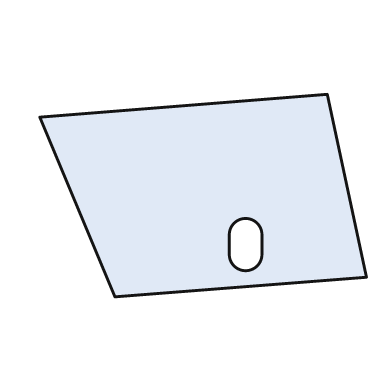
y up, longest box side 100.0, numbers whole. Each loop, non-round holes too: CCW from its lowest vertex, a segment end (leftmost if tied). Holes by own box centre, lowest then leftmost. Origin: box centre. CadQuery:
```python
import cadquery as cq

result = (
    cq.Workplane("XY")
    .moveTo(-27.0, -31.0)
    .lineTo(50.0, -25.0)
    .lineTo(38.0, 31.0)
    .lineTo(-50.0, 24.0)
    .close()
    .moveTo(8.0, -18.0)
    .threePointArc((13.0, -23.0), (18.0, -18.0))
    .lineTo(18.0, -12.0)
    .threePointArc((13.0, -7.0), (8.0, -12.0))
    .close()
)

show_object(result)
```